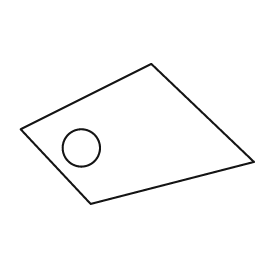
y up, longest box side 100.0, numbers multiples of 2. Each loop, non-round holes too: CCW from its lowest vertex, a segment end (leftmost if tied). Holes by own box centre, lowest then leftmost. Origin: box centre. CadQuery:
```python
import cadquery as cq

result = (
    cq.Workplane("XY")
    .moveTo(-20.0, -30.0)
    .lineTo(50.0, -12.0)
    .lineTo(6.0, 30.0)
    .lineTo(-50.0, 2.0)
    .close()
    .moveTo(-24.0, -6.0)
    .circle(8.0)
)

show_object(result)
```